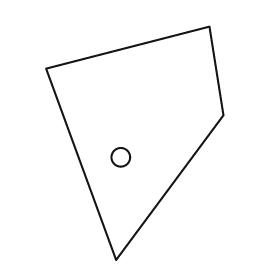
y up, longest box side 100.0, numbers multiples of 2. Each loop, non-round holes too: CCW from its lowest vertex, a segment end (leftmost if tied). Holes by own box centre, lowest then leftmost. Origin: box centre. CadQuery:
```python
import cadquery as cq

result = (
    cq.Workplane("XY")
    .moveTo(-8.0, -50.0)
    .lineTo(38.0, 12.0)
    .lineTo(32.0, 50.0)
    .lineTo(-38.0, 32.0)
    .close()
    .moveTo(-6.0, -6.0)
    .circle(4.0)
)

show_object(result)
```